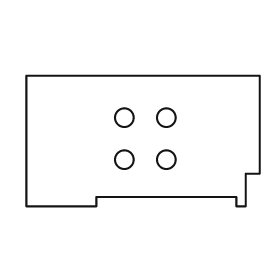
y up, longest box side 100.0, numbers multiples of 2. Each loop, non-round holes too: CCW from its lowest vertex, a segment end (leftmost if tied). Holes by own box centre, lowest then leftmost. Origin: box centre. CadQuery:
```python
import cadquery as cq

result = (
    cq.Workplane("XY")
    .moveTo(-50.0, -28.0)
    .lineTo(-20.0, -28.0)
    .lineTo(-20.0, -24.0)
    .lineTo(40.0, -24.0)
    .lineTo(40.0, -28.0)
    .lineTo(44.0, -28.0)
    .lineTo(44.0, -14.0)
    .lineTo(50.0, -14.0)
    .lineTo(50.0, 28.0)
    .lineTo(-50.0, 28.0)
    .close()
    .moveTo(-8.0, -8.0)
    .circle(4.0)
    .moveTo(10.0, -8.0)
    .circle(4.0)
    .moveTo(-8.0, 10.0)
    .circle(4.0)
    .moveTo(10.0, 10.0)
    .circle(4.0)
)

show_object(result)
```